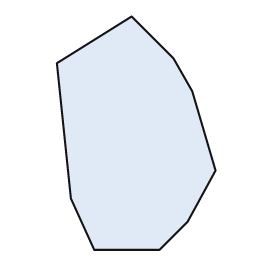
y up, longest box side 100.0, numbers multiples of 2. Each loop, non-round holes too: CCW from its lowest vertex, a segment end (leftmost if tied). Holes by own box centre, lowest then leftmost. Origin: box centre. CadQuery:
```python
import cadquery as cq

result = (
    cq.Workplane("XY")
    .moveTo(-18.0, -50.0)
    .lineTo(10.0, -50.0)
    .lineTo(22.0, -38.0)
    .lineTo(34.0, -16.0)
    .lineTo(24.0, 18.0)
    .lineTo(16.0, 32.0)
    .lineTo(-2.0, 50.0)
    .lineTo(-34.0, 30.0)
    .lineTo(-28.0, -28.0)
    .close()
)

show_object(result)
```